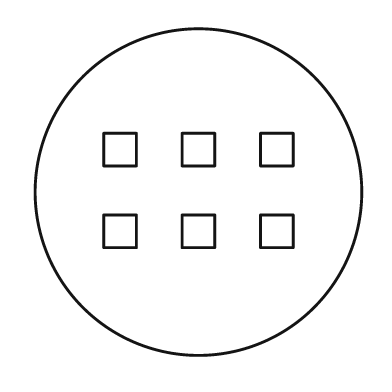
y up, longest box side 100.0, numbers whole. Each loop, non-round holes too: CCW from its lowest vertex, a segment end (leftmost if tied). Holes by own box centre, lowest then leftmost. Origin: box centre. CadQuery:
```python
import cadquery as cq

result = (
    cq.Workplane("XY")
    .moveTo(0.0, 0.0)
    .circle(50.0)
    .moveTo(-29.0, -17.0)
    .lineTo(-19.0, -17.0)
    .lineTo(-19.0, -7.0)
    .lineTo(-29.0, -7.0)
    .close()
    .moveTo(-5.0, -17.0)
    .lineTo(5.0, -17.0)
    .lineTo(5.0, -7.0)
    .lineTo(-5.0, -7.0)
    .close()
    .moveTo(19.0, -17.0)
    .lineTo(29.0, -17.0)
    .lineTo(29.0, -7.0)
    .lineTo(19.0, -7.0)
    .close()
    .moveTo(-29.0, 8.0)
    .lineTo(-19.0, 8.0)
    .lineTo(-19.0, 18.0)
    .lineTo(-29.0, 18.0)
    .close()
    .moveTo(-5.0, 8.0)
    .lineTo(5.0, 8.0)
    .lineTo(5.0, 18.0)
    .lineTo(-5.0, 18.0)
    .close()
    .moveTo(19.0, 8.0)
    .lineTo(29.0, 8.0)
    .lineTo(29.0, 18.0)
    .lineTo(19.0, 18.0)
    .close()
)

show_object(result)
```